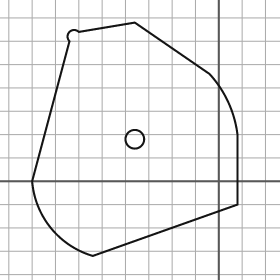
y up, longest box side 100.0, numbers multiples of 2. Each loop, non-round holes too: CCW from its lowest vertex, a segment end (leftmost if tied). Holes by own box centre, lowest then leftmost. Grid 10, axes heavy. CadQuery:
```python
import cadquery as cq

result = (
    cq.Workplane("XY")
    .moveTo(-54.0, -32.0)
    .lineTo(8.0, -10.0)
    .lineTo(8.0, 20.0)
    .threePointArc((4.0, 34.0), (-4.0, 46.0))
    .lineTo(-36.0, 68.0)
    .lineTo(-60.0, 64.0)
    .threePointArc((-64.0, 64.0), (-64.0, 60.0))
    .lineTo(-80.0, 0.0)
    .threePointArc((-72.0, -20.0), (-54.0, -32.0))
    .close()
    .moveTo(-36.0, 18.0)
    .circle(4.0)
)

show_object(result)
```